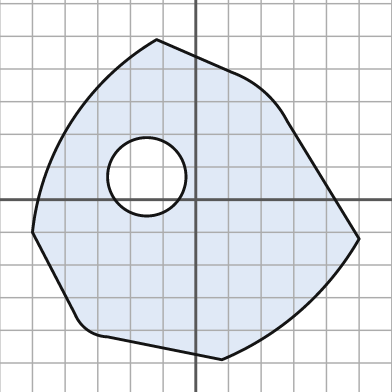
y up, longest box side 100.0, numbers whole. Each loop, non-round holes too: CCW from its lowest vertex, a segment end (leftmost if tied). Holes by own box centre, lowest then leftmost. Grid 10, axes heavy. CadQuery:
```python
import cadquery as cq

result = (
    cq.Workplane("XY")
    .moveTo(8.0, -49.0)
    .threePointArc((32.0, -34.0), (50.0, -12.0))
    .lineTo(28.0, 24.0)
    .threePointArc((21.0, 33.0), (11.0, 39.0))
    .lineTo(-12.0, 49.0)
    .threePointArc((-38.0, 24.0), (-50.0, -10.0))
    .lineTo(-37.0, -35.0)
    .threePointArc((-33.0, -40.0), (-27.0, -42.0))
    .close()
    .moveTo(-15.0, 7.0)
    .circle(12.0)
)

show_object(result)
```